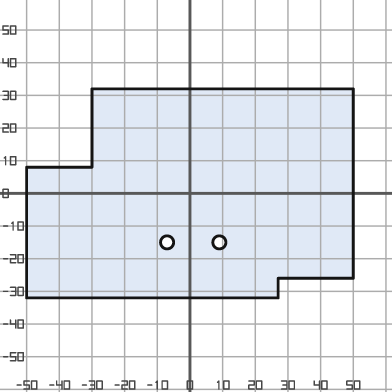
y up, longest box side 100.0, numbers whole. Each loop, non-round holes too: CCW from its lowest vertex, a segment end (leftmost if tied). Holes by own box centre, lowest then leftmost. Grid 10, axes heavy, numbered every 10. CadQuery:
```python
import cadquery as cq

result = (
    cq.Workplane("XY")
    .moveTo(-50.0, -32.0)
    .lineTo(27.0, -32.0)
    .lineTo(27.0, -26.0)
    .lineTo(50.0, -26.0)
    .lineTo(50.0, 32.0)
    .lineTo(-30.0, 32.0)
    .lineTo(-30.0, 8.0)
    .lineTo(-50.0, 8.0)
    .close()
    .moveTo(-7.0, -15.0)
    .circle(2.0)
    .moveTo(9.0, -15.0)
    .circle(2.0)
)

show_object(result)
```